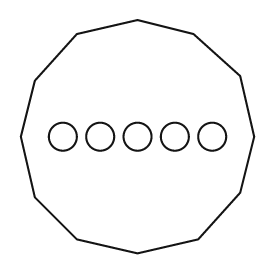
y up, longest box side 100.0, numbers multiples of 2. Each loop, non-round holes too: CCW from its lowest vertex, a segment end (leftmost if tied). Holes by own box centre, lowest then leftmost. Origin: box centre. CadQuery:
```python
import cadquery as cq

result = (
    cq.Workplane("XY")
    .moveTo(0.0, -50.0)
    .lineTo(26.0, -44.0)
    .lineTo(44.0, -24.0)
    .lineTo(50.0, 0.0)
    .lineTo(44.0, 26.0)
    .lineTo(24.0, 44.0)
    .lineTo(0.0, 50.0)
    .lineTo(-26.0, 44.0)
    .lineTo(-44.0, 24.0)
    .lineTo(-50.0, 0.0)
    .lineTo(-44.0, -26.0)
    .lineTo(-26.0, -44.0)
    .close()
    .moveTo(-32.0, 0.0)
    .circle(6.0)
    .moveTo(-16.0, 0.0)
    .circle(6.0)
    .moveTo(0.0, 0.0)
    .circle(6.0)
    .moveTo(16.0, 0.0)
    .circle(6.0)
    .moveTo(32.0, 0.0)
    .circle(6.0)
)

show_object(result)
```